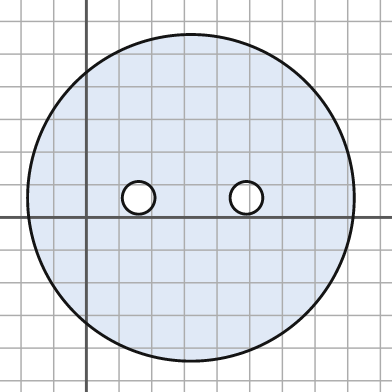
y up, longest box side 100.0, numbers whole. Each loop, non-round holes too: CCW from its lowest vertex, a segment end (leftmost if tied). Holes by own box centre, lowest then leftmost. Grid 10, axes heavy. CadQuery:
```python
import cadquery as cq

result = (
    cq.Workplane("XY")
    .moveTo(32.0, 6.0)
    .circle(50.0)
    .moveTo(16.0, 6.0)
    .circle(5.0)
    .moveTo(49.0, 6.0)
    .circle(5.0)
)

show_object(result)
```